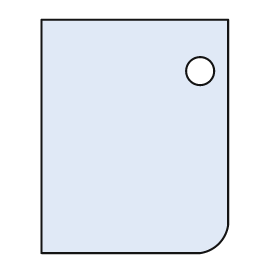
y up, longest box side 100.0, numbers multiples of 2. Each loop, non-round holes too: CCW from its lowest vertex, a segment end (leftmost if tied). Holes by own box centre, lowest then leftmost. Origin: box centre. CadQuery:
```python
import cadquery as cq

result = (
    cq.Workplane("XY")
    .moveTo(-40.0, -50.0)
    .lineTo(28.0, -50.0)
    .threePointArc((36.0, -46.0), (40.0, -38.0))
    .lineTo(40.0, 50.0)
    .lineTo(-40.0, 50.0)
    .close()
    .moveTo(28.0, 28.0)
    .circle(6.0)
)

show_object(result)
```